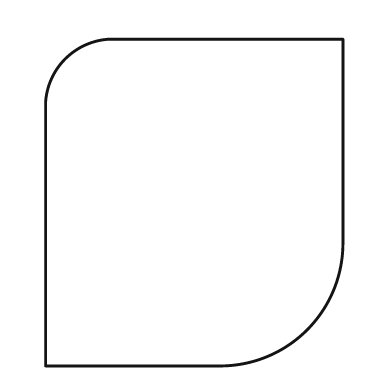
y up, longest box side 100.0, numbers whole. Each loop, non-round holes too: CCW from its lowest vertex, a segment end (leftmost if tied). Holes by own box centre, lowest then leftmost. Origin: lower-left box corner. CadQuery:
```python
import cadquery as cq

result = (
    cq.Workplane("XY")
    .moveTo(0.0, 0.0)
    .lineTo(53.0, 0.0)
    .threePointArc((80.0, 11.0), (91.0, 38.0))
    .lineTo(91.0, 100.0)
    .lineTo(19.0, 100.0)
    .threePointArc((6.0, 94.0), (0.0, 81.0))
    .close()
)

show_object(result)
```